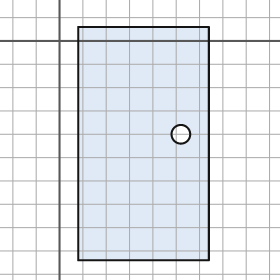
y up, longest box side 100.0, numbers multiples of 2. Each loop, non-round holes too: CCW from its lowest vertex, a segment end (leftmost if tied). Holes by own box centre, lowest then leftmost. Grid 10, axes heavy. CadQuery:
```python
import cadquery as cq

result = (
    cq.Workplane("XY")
    .moveTo(8.0, -94.0)
    .lineTo(64.0, -94.0)
    .lineTo(64.0, 6.0)
    .lineTo(8.0, 6.0)
    .close()
    .moveTo(52.0, -40.0)
    .circle(4.0)
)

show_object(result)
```